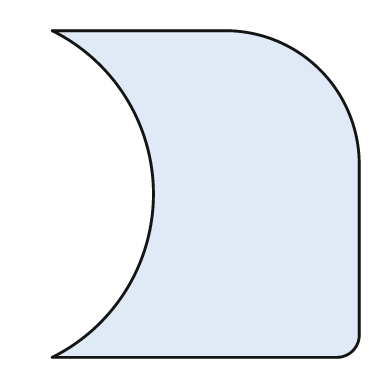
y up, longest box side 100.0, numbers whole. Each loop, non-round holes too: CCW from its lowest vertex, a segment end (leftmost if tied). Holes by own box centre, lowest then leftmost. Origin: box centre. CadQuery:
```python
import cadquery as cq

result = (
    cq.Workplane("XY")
    .moveTo(-47.0, -50.0)
    .lineTo(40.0, -50.0)
    .threePointArc((45.0, -48.0), (47.0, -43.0))
    .lineTo(47.0, 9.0)
    .threePointArc((35.0, 38.0), (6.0, 50.0))
    .lineTo(-47.0, 50.0)
    .threePointArc((-16.0, 0.0), (-47.0, -50.0))
    .close()
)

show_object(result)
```